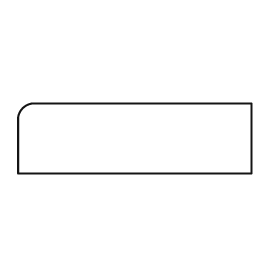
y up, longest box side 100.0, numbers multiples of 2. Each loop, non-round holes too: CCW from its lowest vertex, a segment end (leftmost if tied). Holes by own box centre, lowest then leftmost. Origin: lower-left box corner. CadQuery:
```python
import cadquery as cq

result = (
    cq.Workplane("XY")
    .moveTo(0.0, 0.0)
    .lineTo(100.0, 0.0)
    .lineTo(100.0, 30.0)
    .lineTo(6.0, 30.0)
    .threePointArc((2.0, 28.0), (0.0, 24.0))
    .close()
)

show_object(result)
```